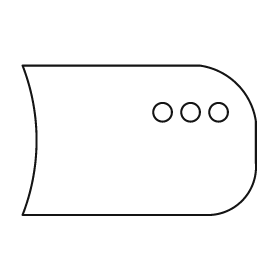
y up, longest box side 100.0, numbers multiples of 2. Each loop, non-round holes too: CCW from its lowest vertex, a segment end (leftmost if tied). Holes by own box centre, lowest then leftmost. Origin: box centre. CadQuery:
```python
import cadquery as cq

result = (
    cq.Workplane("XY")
    .moveTo(-50.0, -32.0)
    .lineTo(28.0, -32.0)
    .threePointArc((44.0, -26.0), (50.0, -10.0))
    .lineTo(50.0, 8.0)
    .threePointArc((42.0, 24.0), (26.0, 32.0))
    .lineTo(-50.0, 32.0)
    .threePointArc((-44.0, 0.0), (-50.0, -32.0))
    .close()
    .moveTo(10.0, 12.0)
    .circle(4.0)
    .moveTo(22.0, 12.0)
    .circle(4.0)
    .moveTo(34.0, 12.0)
    .circle(4.0)
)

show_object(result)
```